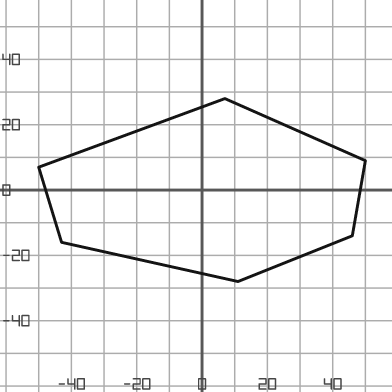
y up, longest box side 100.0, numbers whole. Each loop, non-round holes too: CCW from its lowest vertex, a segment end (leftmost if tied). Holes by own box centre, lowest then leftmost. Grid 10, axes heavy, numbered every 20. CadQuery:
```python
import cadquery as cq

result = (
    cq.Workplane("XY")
    .moveTo(11.0, -28.0)
    .lineTo(46.0, -14.0)
    .lineTo(50.0, 9.0)
    .lineTo(7.0, 28.0)
    .lineTo(-50.0, 7.0)
    .lineTo(-43.0, -16.0)
    .close()
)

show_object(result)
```